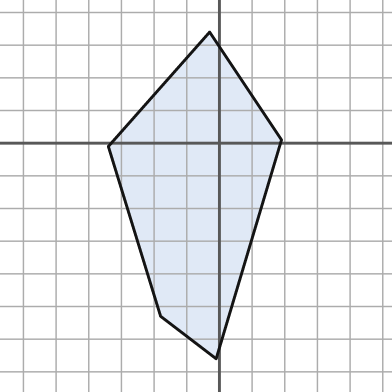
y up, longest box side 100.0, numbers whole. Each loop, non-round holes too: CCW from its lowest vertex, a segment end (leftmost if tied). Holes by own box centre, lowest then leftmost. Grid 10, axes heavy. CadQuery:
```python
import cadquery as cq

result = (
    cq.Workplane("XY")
    .moveTo(-1.0, -66.0)
    .lineTo(19.0, 1.0)
    .lineTo(-3.0, 34.0)
    .lineTo(-34.0, -1.0)
    .lineTo(-18.0, -53.0)
    .close()
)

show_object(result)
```